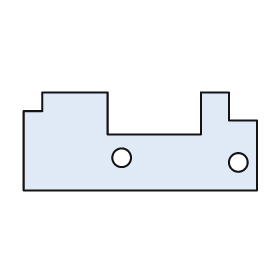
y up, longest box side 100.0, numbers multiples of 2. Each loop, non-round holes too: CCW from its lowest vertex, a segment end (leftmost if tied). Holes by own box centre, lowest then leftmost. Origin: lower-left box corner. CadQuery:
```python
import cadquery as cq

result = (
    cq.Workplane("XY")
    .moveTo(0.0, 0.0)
    .lineTo(100.0, 0.0)
    .lineTo(100.0, 30.0)
    .lineTo(88.0, 30.0)
    .lineTo(88.0, 42.0)
    .lineTo(76.0, 42.0)
    .lineTo(76.0, 24.0)
    .lineTo(36.0, 24.0)
    .lineTo(36.0, 42.0)
    .lineTo(8.0, 42.0)
    .lineTo(8.0, 34.0)
    .lineTo(0.0, 34.0)
    .close()
    .moveTo(92.0, 12.0)
    .circle(4.0)
    .moveTo(42.0, 14.0)
    .circle(4.0)
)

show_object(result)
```